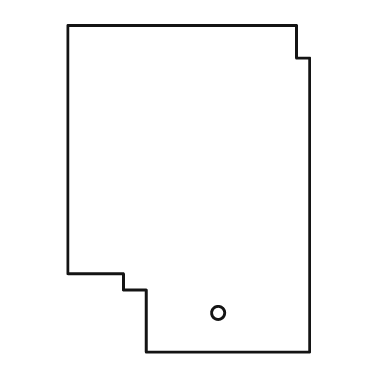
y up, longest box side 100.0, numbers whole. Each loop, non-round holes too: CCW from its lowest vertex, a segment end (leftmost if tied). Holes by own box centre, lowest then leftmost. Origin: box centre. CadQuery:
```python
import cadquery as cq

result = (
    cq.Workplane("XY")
    .moveTo(-13.0, -50.0)
    .lineTo(37.0, -50.0)
    .lineTo(37.0, 40.0)
    .lineTo(33.0, 40.0)
    .lineTo(33.0, 50.0)
    .lineTo(-37.0, 50.0)
    .lineTo(-37.0, -26.0)
    .lineTo(-20.0, -26.0)
    .lineTo(-20.0, -31.0)
    .lineTo(-13.0, -31.0)
    .close()
    .moveTo(9.0, -38.0)
    .circle(2.0)
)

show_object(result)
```